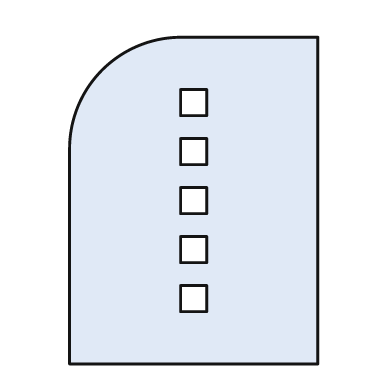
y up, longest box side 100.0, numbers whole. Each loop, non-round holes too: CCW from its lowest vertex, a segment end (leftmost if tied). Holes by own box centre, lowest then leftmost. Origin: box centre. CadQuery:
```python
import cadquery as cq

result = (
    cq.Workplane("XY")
    .moveTo(-38.0, -50.0)
    .lineTo(38.0, -50.0)
    .lineTo(38.0, 50.0)
    .lineTo(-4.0, 50.0)
    .threePointArc((-28.0, 40.0), (-38.0, 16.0))
    .close()
    .moveTo(-4.0, -34.0)
    .lineTo(4.0, -34.0)
    .lineTo(4.0, -26.0)
    .lineTo(-4.0, -26.0)
    .close()
    .moveTo(-4.0, -19.0)
    .lineTo(4.0, -19.0)
    .lineTo(4.0, -11.0)
    .lineTo(-4.0, -11.0)
    .close()
    .moveTo(-4.0, -4.0)
    .lineTo(4.0, -4.0)
    .lineTo(4.0, 4.0)
    .lineTo(-4.0, 4.0)
    .close()
    .moveTo(-4.0, 11.0)
    .lineTo(4.0, 11.0)
    .lineTo(4.0, 19.0)
    .lineTo(-4.0, 19.0)
    .close()
    .moveTo(-4.0, 26.0)
    .lineTo(4.0, 26.0)
    .lineTo(4.0, 34.0)
    .lineTo(-4.0, 34.0)
    .close()
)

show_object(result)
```